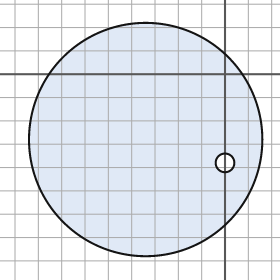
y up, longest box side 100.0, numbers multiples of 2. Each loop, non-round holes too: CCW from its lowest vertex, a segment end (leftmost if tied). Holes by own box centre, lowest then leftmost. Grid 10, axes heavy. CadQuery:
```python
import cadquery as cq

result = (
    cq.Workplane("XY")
    .moveTo(-34.0, -28.0)
    .circle(50.0)
    .moveTo(0.0, -38.0)
    .circle(4.0)
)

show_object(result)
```